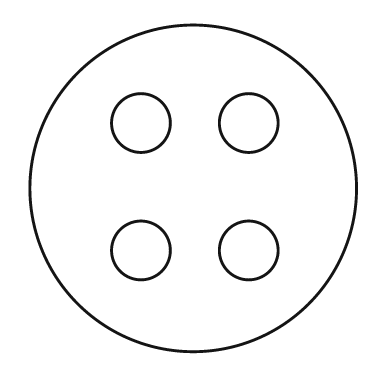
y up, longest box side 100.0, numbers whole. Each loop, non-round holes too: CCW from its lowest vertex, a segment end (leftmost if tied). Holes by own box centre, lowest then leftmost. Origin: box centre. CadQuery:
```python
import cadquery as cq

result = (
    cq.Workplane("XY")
    .moveTo(0.0, 0.0)
    .circle(50.0)
    .moveTo(-16.0, -19.0)
    .circle(9.0)
    .moveTo(17.0, -19.0)
    .circle(9.0)
    .moveTo(-16.0, 20.0)
    .circle(9.0)
    .moveTo(17.0, 20.0)
    .circle(9.0)
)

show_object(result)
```